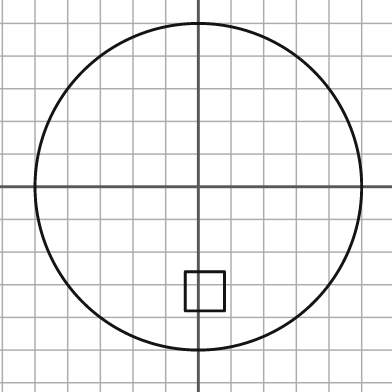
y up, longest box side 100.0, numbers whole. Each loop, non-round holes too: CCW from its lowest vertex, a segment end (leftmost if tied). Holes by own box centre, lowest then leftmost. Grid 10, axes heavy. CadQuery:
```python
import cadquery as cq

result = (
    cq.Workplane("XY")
    .moveTo(0.0, 0.0)
    .circle(50.0)
    .moveTo(-4.0, -38.0)
    .lineTo(8.0, -38.0)
    .lineTo(8.0, -26.0)
    .lineTo(-4.0, -26.0)
    .close()
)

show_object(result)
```